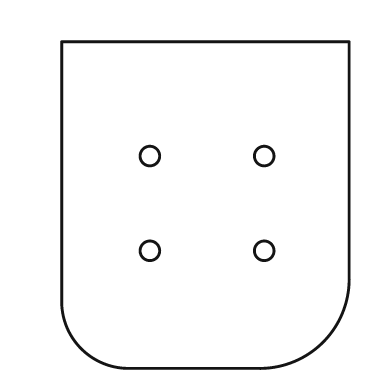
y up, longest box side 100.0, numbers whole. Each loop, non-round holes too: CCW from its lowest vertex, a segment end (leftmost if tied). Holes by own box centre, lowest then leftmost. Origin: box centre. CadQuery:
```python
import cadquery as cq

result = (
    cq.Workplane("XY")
    .moveTo(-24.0, -50.0)
    .lineTo(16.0, -50.0)
    .threePointArc((36.0, -42.0), (44.0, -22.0))
    .lineTo(44.0, 50.0)
    .lineTo(-44.0, 50.0)
    .lineTo(-44.0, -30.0)
    .threePointArc((-38.0, -44.0), (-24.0, -50.0))
    .close()
    .moveTo(-17.0, -14.0)
    .circle(3.0)
    .moveTo(18.0, -14.0)
    .circle(3.0)
    .moveTo(-17.0, 15.0)
    .circle(3.0)
    .moveTo(18.0, 15.0)
    .circle(3.0)
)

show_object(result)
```